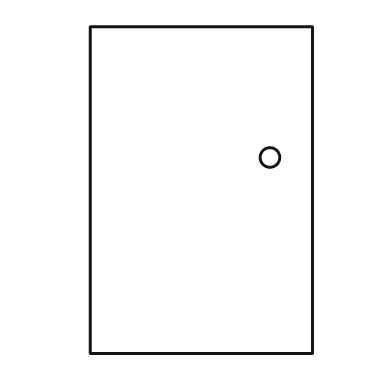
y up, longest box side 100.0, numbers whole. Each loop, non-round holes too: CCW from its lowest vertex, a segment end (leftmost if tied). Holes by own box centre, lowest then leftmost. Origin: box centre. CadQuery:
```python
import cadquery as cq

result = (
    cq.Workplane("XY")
    .moveTo(-34.0, -50.0)
    .lineTo(34.0, -50.0)
    .lineTo(34.0, 50.0)
    .lineTo(-34.0, 50.0)
    .close()
    .moveTo(21.0, 10.0)
    .circle(3.0)
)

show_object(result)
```